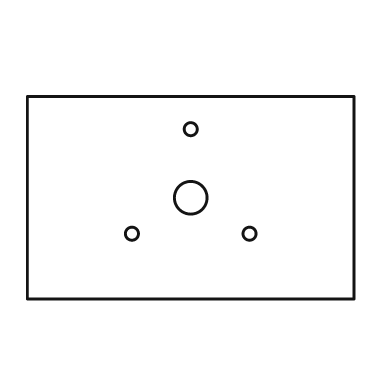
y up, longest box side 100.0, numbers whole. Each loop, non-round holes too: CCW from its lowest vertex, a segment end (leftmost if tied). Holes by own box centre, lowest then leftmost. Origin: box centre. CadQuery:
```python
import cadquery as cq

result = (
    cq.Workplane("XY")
    .moveTo(-50.0, -31.0)
    .lineTo(50.0, -31.0)
    .lineTo(50.0, 31.0)
    .lineTo(-50.0, 31.0)
    .close()
    .moveTo(-18.0, -11.0)
    .circle(2.0)
    .moveTo(18.0, -11.0)
    .circle(2.0)
    .moveTo(0.0, 0.0)
    .circle(5.0)
    .moveTo(0.0, 21.0)
    .circle(2.0)
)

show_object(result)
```